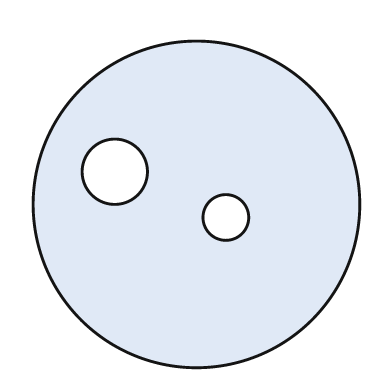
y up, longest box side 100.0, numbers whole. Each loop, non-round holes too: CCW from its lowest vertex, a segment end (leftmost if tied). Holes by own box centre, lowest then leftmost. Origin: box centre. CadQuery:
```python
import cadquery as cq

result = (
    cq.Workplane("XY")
    .moveTo(0.0, 0.0)
    .circle(50.0)
    .moveTo(9.0, -4.0)
    .circle(7.0)
    .moveTo(-25.0, 10.0)
    .circle(10.0)
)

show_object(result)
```